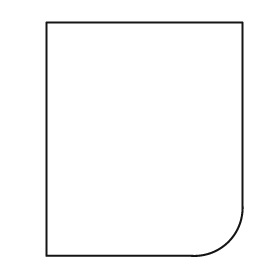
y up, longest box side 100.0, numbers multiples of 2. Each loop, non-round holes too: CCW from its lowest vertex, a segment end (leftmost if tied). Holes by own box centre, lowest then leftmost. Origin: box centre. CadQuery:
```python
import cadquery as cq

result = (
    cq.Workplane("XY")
    .moveTo(-42.0, -50.0)
    .lineTo(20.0, -50.0)
    .threePointArc((36.0, -44.0), (42.0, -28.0))
    .lineTo(42.0, 50.0)
    .lineTo(-42.0, 50.0)
    .close()
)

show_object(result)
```